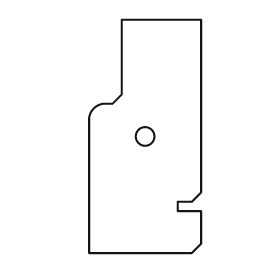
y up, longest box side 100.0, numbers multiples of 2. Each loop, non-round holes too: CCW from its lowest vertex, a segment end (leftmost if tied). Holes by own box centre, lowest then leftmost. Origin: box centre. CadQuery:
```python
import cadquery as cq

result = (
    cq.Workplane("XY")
    .moveTo(-24.0, -50.0)
    .lineTo(20.0, -50.0)
    .lineTo(24.0, -46.0)
    .lineTo(24.0, -32.0)
    .lineTo(14.0, -32.0)
    .lineTo(14.0, -28.0)
    .lineTo(20.0, -28.0)
    .lineTo(24.0, -24.0)
    .lineTo(24.0, 50.0)
    .lineTo(-10.0, 50.0)
    .lineTo(-10.0, 18.0)
    .lineTo(-14.0, 14.0)
    .lineTo(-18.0, 14.0)
    .threePointArc((-22.0, 12.0), (-24.0, 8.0))
    .close()
    .moveTo(0.0, 0.0)
    .circle(4.0)
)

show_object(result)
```